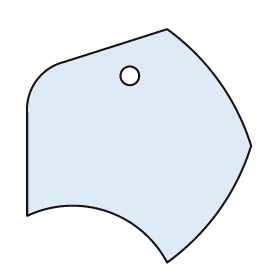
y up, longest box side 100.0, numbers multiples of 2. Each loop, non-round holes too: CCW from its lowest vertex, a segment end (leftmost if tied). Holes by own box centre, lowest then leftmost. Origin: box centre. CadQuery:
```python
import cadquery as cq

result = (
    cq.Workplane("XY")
    .moveTo(12.0, -50.0)
    .threePointArc((34.0, -28.0), (48.0, 0.0))
    .threePointArc((34.0, 28.0), (12.0, 50.0))
    .lineTo(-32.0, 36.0)
    .threePointArc((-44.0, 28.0), (-48.0, 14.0))
    .lineTo(-48.0, -30.0)
    .threePointArc((-14.0, -28.0), (12.0, -50.0))
    .close()
    .moveTo(-4.0, 30.0)
    .circle(4.0)
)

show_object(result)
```